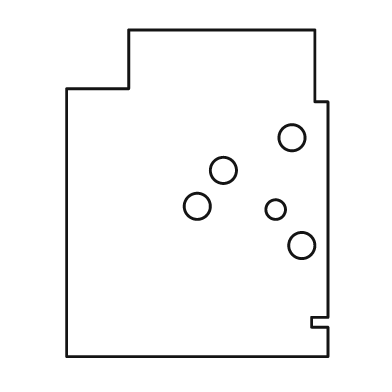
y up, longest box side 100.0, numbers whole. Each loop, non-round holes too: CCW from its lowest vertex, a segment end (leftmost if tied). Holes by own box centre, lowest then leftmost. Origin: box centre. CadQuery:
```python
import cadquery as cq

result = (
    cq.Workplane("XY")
    .moveTo(-40.0, -50.0)
    .lineTo(40.0, -50.0)
    .lineTo(40.0, -41.0)
    .lineTo(35.0, -41.0)
    .lineTo(35.0, -38.0)
    .lineTo(40.0, -38.0)
    .lineTo(40.0, 28.0)
    .lineTo(36.0, 28.0)
    .lineTo(36.0, 50.0)
    .lineTo(-21.0, 50.0)
    .lineTo(-21.0, 32.0)
    .lineTo(-40.0, 32.0)
    .close()
    .moveTo(32.0, -16.0)
    .circle(4.0)
    .moveTo(24.0, -5.0)
    .circle(3.0)
    .moveTo(0.0, -4.0)
    .circle(4.0)
    .moveTo(8.0, 7.0)
    .circle(4.0)
    .moveTo(29.0, 17.0)
    .circle(4.0)
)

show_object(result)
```